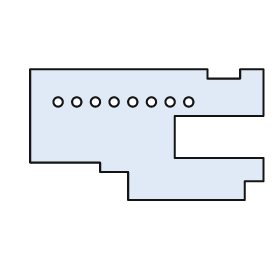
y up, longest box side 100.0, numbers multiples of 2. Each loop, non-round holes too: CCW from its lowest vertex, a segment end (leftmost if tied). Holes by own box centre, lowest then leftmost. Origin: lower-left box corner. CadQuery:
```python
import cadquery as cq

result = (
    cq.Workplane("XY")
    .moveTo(42.0, 0.0)
    .lineTo(92.0, 0.0)
    .lineTo(92.0, 8.0)
    .lineTo(100.0, 8.0)
    .lineTo(100.0, 18.0)
    .lineTo(62.0, 18.0)
    .lineTo(62.0, 36.0)
    .lineTo(100.0, 36.0)
    .lineTo(100.0, 56.0)
    .lineTo(90.0, 56.0)
    .lineTo(90.0, 52.0)
    .lineTo(76.0, 52.0)
    .lineTo(76.0, 56.0)
    .lineTo(0.0, 56.0)
    .lineTo(0.0, 16.0)
    .lineTo(30.0, 16.0)
    .lineTo(30.0, 12.0)
    .lineTo(42.0, 12.0)
    .close()
    .moveTo(12.0, 42.0)
    .circle(2.0)
    .moveTo(20.0, 42.0)
    .circle(2.0)
    .moveTo(28.0, 42.0)
    .circle(2.0)
    .moveTo(36.0, 42.0)
    .circle(2.0)
    .moveTo(44.0, 42.0)
    .circle(2.0)
    .moveTo(52.0, 42.0)
    .circle(2.0)
    .moveTo(60.0, 42.0)
    .circle(2.0)
    .moveTo(68.0, 42.0)
    .circle(2.0)
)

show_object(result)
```